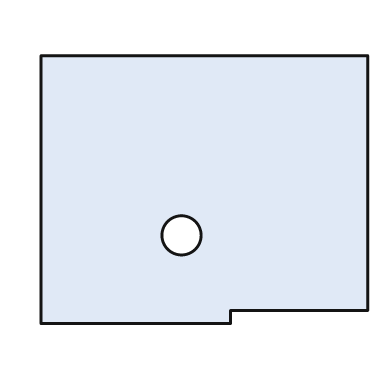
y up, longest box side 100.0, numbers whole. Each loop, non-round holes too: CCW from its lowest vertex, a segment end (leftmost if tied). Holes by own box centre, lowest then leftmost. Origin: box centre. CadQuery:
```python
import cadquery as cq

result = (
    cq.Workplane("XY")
    .moveTo(-50.0, -41.0)
    .lineTo(8.0, -41.0)
    .lineTo(8.0, -37.0)
    .lineTo(50.0, -37.0)
    .lineTo(50.0, 41.0)
    .lineTo(-50.0, 41.0)
    .close()
    .moveTo(-7.0, -14.0)
    .circle(6.0)
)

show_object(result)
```